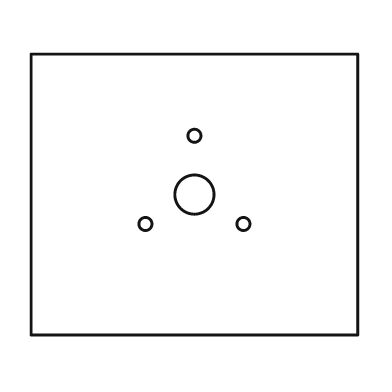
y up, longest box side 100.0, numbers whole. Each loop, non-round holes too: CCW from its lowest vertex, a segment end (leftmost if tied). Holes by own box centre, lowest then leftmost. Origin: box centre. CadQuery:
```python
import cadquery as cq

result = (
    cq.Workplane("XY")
    .moveTo(-50.0, -43.0)
    .lineTo(50.0, -43.0)
    .lineTo(50.0, 43.0)
    .lineTo(-50.0, 43.0)
    .close()
    .moveTo(-15.0, -9.0)
    .circle(2.0)
    .moveTo(15.0, -9.0)
    .circle(2.0)
    .moveTo(0.0, 0.0)
    .circle(6.0)
    .moveTo(0.0, 18.0)
    .circle(2.0)
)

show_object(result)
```